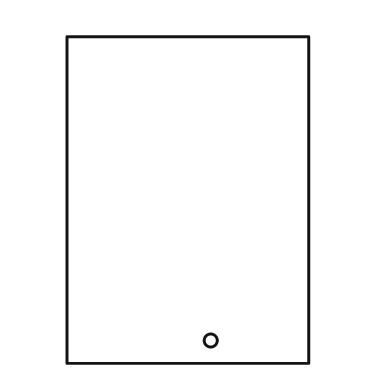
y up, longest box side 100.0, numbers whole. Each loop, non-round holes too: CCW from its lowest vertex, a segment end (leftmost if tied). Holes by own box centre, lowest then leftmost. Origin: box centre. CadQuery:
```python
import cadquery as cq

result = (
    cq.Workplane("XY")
    .moveTo(-37.0, -50.0)
    .lineTo(37.0, -50.0)
    .lineTo(37.0, 50.0)
    .lineTo(-37.0, 50.0)
    .close()
    .moveTo(7.0, -43.0)
    .circle(2.0)
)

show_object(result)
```